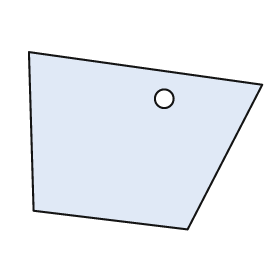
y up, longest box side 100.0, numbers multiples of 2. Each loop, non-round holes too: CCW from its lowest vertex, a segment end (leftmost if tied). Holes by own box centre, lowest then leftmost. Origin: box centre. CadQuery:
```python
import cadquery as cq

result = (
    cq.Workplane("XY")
    .moveTo(18.0, -38.0)
    .lineTo(50.0, 24.0)
    .lineTo(-50.0, 38.0)
    .lineTo(-48.0, -30.0)
    .close()
    .moveTo(8.0, 18.0)
    .circle(4.0)
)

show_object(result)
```